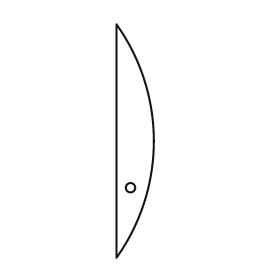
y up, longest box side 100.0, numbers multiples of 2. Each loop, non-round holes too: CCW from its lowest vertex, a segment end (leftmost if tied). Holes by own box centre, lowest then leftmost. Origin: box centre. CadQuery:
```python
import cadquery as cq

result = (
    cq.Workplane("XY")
    .moveTo(-8.0, -50.0)
    .threePointArc((8.0, 0.0), (-8.0, 50.0))
    .close()
    .moveTo(-2.0, -20.0)
    .circle(2.0)
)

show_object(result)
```